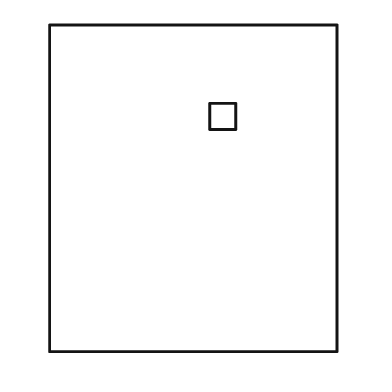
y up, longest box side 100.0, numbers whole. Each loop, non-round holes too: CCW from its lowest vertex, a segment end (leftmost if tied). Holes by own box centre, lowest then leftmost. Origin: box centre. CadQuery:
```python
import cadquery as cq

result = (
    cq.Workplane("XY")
    .moveTo(-44.0, -50.0)
    .lineTo(44.0, -50.0)
    .lineTo(44.0, 50.0)
    .lineTo(-44.0, 50.0)
    .close()
    .moveTo(5.0, 18.0)
    .lineTo(13.0, 18.0)
    .lineTo(13.0, 26.0)
    .lineTo(5.0, 26.0)
    .close()
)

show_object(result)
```